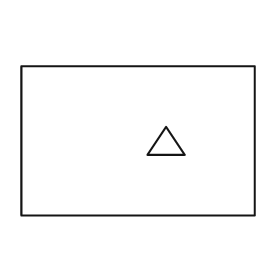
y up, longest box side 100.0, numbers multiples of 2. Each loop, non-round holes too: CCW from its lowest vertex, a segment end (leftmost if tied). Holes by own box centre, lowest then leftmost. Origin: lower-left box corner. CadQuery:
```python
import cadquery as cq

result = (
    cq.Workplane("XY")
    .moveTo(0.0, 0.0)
    .lineTo(100.0, 0.0)
    .lineTo(100.0, 64.0)
    .lineTo(0.0, 64.0)
    .close()
    .moveTo(54.0, 26.0)
    .lineTo(70.0, 26.0)
    .lineTo(62.0, 38.0)
    .close()
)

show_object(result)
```